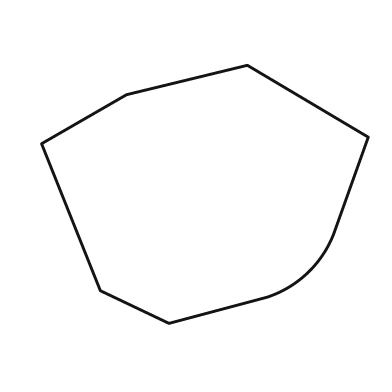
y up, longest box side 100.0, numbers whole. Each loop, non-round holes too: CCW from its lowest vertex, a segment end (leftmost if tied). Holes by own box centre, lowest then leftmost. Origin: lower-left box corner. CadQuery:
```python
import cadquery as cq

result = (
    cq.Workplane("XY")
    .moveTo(39.0, 0.0)
    .lineTo(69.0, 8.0)
    .threePointArc((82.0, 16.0), (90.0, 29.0))
    .lineTo(100.0, 57.0)
    .lineTo(63.0, 79.0)
    .lineTo(26.0, 70.0)
    .lineTo(0.0, 55.0)
    .lineTo(18.0, 10.0)
    .close()
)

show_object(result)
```